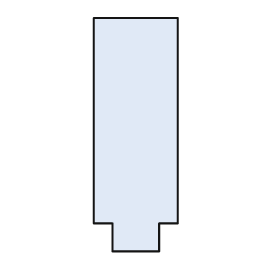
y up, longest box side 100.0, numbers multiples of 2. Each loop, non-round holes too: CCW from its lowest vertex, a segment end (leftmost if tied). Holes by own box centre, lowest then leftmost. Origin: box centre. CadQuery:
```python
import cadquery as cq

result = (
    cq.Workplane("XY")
    .moveTo(-10.0, -50.0)
    .lineTo(10.0, -50.0)
    .lineTo(10.0, -38.0)
    .lineTo(18.0, -38.0)
    .lineTo(18.0, 50.0)
    .lineTo(-18.0, 50.0)
    .lineTo(-18.0, -38.0)
    .lineTo(-10.0, -38.0)
    .close()
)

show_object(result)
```